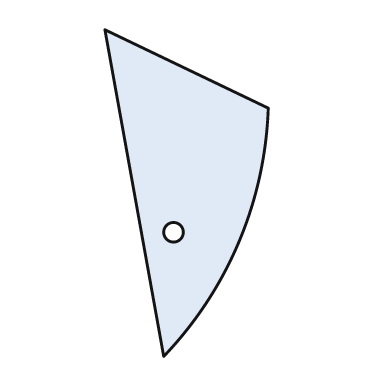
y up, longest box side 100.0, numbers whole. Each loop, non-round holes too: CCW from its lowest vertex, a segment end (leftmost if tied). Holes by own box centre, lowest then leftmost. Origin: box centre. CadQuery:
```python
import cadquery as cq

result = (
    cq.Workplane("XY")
    .moveTo(-7.0, -50.0)
    .threePointArc((16.0, -15.0), (25.0, 26.0))
    .lineTo(-25.0, 50.0)
    .close()
    .moveTo(-4.0, -12.0)
    .circle(3.0)
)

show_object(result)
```